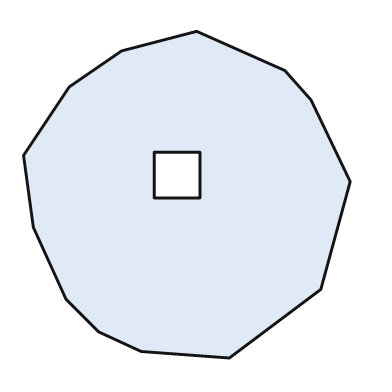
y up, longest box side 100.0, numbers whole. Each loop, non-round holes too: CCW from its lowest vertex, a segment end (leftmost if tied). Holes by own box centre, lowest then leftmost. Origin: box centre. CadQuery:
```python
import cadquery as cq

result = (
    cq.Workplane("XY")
    .moveTo(13.0, -50.0)
    .lineTo(41.0, -29.0)
    .lineTo(50.0, 4.0)
    .lineTo(38.0, 29.0)
    .lineTo(30.0, 38.0)
    .lineTo(3.0, 50.0)
    .lineTo(-20.0, 44.0)
    .lineTo(-36.0, 33.0)
    .lineTo(-50.0, 12.0)
    .lineTo(-47.0, -10.0)
    .lineTo(-37.0, -32.0)
    .lineTo(-27.0, -42.0)
    .lineTo(-14.0, -48.0)
    .close()
    .moveTo(-10.0, -1.0)
    .lineTo(4.0, -1.0)
    .lineTo(4.0, 13.0)
    .lineTo(-10.0, 13.0)
    .close()
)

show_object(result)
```